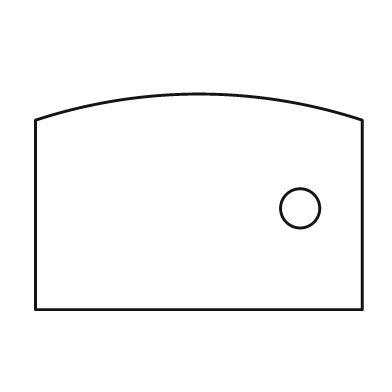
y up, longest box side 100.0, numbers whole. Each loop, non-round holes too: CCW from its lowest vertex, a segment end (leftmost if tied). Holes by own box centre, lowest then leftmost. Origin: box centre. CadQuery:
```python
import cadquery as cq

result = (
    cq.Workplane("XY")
    .moveTo(-50.0, -33.0)
    .lineTo(50.0, -33.0)
    .lineTo(50.0, 25.0)
    .threePointArc((0.0, 33.0), (-50.0, 25.0))
    .close()
    .moveTo(31.0, -2.0)
    .circle(6.0)
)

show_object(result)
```